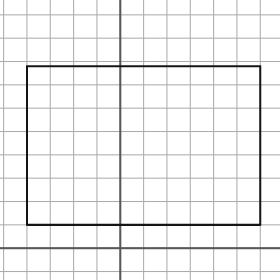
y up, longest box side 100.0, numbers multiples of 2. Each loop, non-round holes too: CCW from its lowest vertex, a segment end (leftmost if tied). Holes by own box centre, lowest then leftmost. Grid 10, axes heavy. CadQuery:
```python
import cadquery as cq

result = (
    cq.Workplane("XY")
    .moveTo(-40.0, 10.0)
    .lineTo(60.0, 10.0)
    .lineTo(60.0, 78.0)
    .lineTo(-40.0, 78.0)
    .close()
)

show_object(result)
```